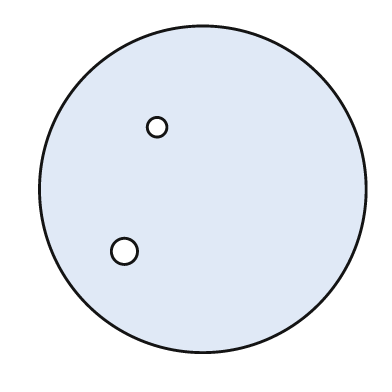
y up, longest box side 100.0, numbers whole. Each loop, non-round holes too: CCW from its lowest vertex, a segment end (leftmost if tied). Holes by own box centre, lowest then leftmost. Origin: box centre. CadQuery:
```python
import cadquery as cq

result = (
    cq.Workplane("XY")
    .moveTo(0.0, 0.0)
    .circle(50.0)
    .moveTo(-24.0, -19.0)
    .circle(4.0)
    .moveTo(-14.0, 19.0)
    .circle(3.0)
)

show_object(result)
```